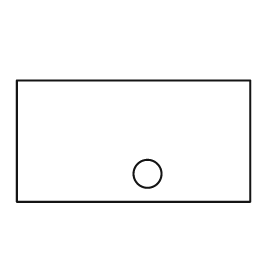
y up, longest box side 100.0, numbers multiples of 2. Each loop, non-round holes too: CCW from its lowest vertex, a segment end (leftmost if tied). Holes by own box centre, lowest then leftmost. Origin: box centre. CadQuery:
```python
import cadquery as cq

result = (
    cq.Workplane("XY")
    .moveTo(-50.0, -26.0)
    .lineTo(50.0, -26.0)
    .lineTo(50.0, 26.0)
    .lineTo(-50.0, 26.0)
    .close()
    .moveTo(6.0, -14.0)
    .circle(6.0)
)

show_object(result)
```